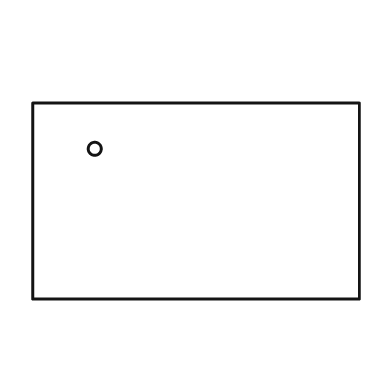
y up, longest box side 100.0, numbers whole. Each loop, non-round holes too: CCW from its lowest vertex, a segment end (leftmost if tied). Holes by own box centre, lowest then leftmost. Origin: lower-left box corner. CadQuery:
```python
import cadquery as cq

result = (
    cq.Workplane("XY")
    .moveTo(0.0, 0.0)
    .lineTo(100.0, 0.0)
    .lineTo(100.0, 60.0)
    .lineTo(0.0, 60.0)
    .close()
    .moveTo(19.0, 46.0)
    .circle(2.0)
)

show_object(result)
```